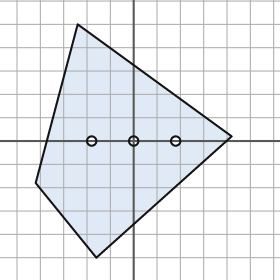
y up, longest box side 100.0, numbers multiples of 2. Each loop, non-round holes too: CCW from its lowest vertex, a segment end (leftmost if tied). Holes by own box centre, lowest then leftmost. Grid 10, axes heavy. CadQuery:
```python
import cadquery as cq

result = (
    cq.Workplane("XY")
    .moveTo(-16.0, -50.0)
    .lineTo(42.0, 2.0)
    .lineTo(-24.0, 50.0)
    .lineTo(-42.0, -18.0)
    .close()
    .moveTo(-18.0, 0.0)
    .circle(2.0)
    .moveTo(0.0, 0.0)
    .circle(2.0)
    .moveTo(18.0, 0.0)
    .circle(2.0)
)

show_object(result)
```